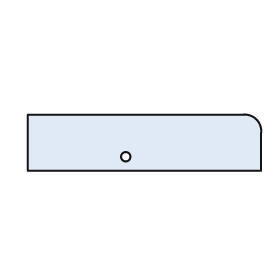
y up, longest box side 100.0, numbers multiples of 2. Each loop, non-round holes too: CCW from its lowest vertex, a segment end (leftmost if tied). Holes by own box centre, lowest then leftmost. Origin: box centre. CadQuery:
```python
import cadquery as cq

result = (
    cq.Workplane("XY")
    .moveTo(-50.0, -12.0)
    .lineTo(50.0, -12.0)
    .lineTo(50.0, 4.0)
    .threePointArc((48.0, 10.0), (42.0, 12.0))
    .lineTo(-50.0, 12.0)
    .close()
    .moveTo(-8.0, -6.0)
    .circle(2.0)
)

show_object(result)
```